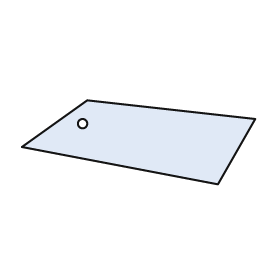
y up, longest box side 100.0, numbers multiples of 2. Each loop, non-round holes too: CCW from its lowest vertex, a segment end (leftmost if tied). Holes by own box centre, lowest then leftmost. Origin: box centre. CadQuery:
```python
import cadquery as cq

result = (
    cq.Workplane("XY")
    .moveTo(34.0, -18.0)
    .lineTo(50.0, 10.0)
    .lineTo(-22.0, 18.0)
    .lineTo(-50.0, -2.0)
    .close()
    .moveTo(-24.0, 8.0)
    .circle(2.0)
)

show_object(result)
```